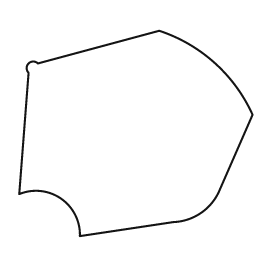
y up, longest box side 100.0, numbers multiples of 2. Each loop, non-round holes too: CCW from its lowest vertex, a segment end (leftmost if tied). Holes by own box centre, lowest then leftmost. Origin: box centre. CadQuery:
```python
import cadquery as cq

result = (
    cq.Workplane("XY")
    .moveTo(-24.0, -44.0)
    .lineTo(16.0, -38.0)
    .threePointArc((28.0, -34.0), (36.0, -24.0))
    .lineTo(50.0, 8.0)
    .threePointArc((34.0, 30.0), (10.0, 44.0))
    .lineTo(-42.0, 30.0)
    .threePointArc((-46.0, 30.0), (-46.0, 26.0))
    .lineTo(-50.0, -26.0)
    .threePointArc((-32.0, -28.0), (-24.0, -44.0))
    .close()
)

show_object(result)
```